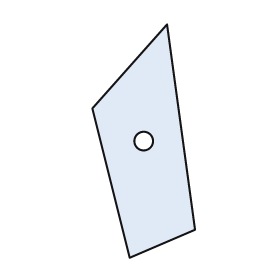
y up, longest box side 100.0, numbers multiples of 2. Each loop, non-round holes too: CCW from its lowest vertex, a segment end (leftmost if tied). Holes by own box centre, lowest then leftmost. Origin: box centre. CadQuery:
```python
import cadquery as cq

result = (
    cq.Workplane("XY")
    .moveTo(-6.0, -50.0)
    .lineTo(22.0, -38.0)
    .lineTo(10.0, 50.0)
    .lineTo(-22.0, 14.0)
    .close()
    .moveTo(0.0, 0.0)
    .circle(4.0)
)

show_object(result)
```